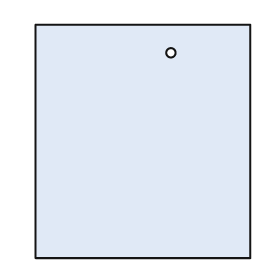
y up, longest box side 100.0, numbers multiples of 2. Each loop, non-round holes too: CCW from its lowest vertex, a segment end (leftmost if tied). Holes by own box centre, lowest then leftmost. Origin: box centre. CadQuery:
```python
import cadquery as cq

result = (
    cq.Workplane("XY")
    .moveTo(-46.0, -50.0)
    .lineTo(46.0, -50.0)
    .lineTo(46.0, 50.0)
    .lineTo(-46.0, 50.0)
    .close()
    .moveTo(12.0, 38.0)
    .circle(2.0)
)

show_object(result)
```